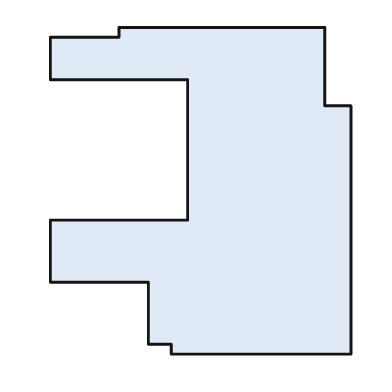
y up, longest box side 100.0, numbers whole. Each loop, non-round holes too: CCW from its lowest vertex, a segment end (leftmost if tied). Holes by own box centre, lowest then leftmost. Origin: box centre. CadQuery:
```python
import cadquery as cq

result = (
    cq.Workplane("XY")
    .moveTo(-9.0, -50.0)
    .lineTo(46.0, -50.0)
    .lineTo(46.0, 26.0)
    .lineTo(38.0, 26.0)
    .lineTo(38.0, 50.0)
    .lineTo(-25.0, 50.0)
    .lineTo(-25.0, 47.0)
    .lineTo(-46.0, 47.0)
    .lineTo(-46.0, 34.0)
    .lineTo(-4.0, 34.0)
    .lineTo(-4.0, -9.0)
    .lineTo(-46.0, -9.0)
    .lineTo(-46.0, -28.0)
    .lineTo(-16.0, -28.0)
    .lineTo(-16.0, -47.0)
    .lineTo(-9.0, -47.0)
    .close()
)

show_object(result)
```